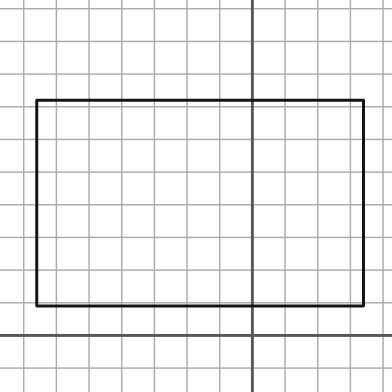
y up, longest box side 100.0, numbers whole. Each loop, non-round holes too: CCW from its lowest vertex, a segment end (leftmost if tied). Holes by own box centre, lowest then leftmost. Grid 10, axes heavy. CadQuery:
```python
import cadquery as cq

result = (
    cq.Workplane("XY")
    .moveTo(-66.0, 9.0)
    .lineTo(34.0, 9.0)
    .lineTo(34.0, 72.0)
    .lineTo(-66.0, 72.0)
    .close()
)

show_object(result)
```